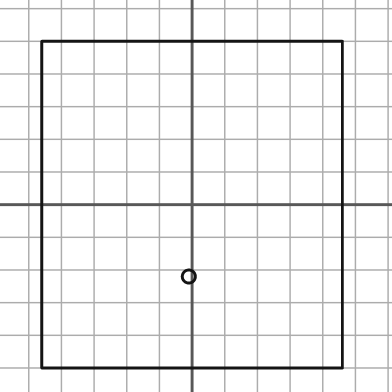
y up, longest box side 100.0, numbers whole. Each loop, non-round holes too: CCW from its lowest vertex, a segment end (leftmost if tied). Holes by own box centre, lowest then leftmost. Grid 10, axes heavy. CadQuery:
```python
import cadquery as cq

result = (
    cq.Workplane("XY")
    .moveTo(-46.0, -50.0)
    .lineTo(46.0, -50.0)
    .lineTo(46.0, 50.0)
    .lineTo(-46.0, 50.0)
    .close()
    .moveTo(-1.0, -22.0)
    .circle(2.0)
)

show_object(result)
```